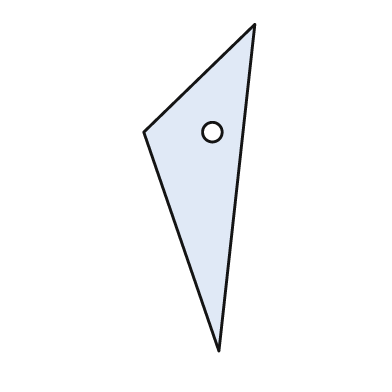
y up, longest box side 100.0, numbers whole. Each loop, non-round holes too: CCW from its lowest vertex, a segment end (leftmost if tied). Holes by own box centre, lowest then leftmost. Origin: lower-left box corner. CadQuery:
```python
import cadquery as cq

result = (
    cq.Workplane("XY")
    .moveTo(23.0, 0.0)
    .lineTo(34.0, 100.0)
    .lineTo(0.0, 67.0)
    .close()
    .moveTo(21.0, 67.0)
    .circle(3.0)
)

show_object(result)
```